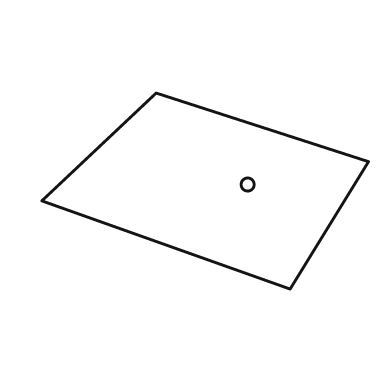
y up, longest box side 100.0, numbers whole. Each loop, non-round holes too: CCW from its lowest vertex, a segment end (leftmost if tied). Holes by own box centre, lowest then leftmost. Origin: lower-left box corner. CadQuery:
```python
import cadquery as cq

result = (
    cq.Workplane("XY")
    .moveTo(76.0, 0.0)
    .lineTo(100.0, 39.0)
    .lineTo(35.0, 60.0)
    .lineTo(0.0, 27.0)
    .close()
    .moveTo(63.0, 32.0)
    .circle(2.0)
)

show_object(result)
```